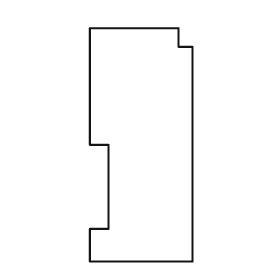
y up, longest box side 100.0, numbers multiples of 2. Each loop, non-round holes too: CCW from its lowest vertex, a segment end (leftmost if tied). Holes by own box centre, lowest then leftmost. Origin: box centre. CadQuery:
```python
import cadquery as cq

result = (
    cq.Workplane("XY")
    .moveTo(-22.0, -50.0)
    .lineTo(22.0, -50.0)
    .lineTo(22.0, 42.0)
    .lineTo(16.0, 42.0)
    .lineTo(16.0, 50.0)
    .lineTo(-22.0, 50.0)
    .lineTo(-22.0, 0.0)
    .lineTo(-14.0, 0.0)
    .lineTo(-14.0, -36.0)
    .lineTo(-22.0, -36.0)
    .close()
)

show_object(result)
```